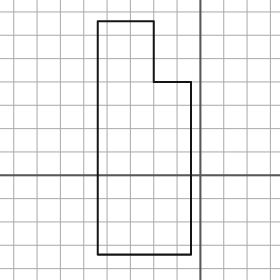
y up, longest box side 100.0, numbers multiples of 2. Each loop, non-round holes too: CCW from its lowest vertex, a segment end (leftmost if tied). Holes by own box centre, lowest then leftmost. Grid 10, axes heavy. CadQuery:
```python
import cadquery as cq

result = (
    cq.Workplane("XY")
    .moveTo(-44.0, -34.0)
    .lineTo(-4.0, -34.0)
    .lineTo(-4.0, 40.0)
    .lineTo(-20.0, 40.0)
    .lineTo(-20.0, 66.0)
    .lineTo(-44.0, 66.0)
    .close()
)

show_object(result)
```